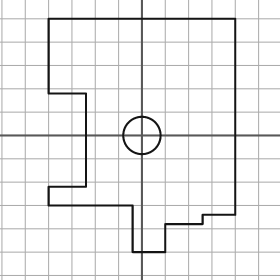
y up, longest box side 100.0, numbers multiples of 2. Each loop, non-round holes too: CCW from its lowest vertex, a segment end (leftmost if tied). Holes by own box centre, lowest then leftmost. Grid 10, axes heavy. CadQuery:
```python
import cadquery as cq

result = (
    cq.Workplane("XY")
    .moveTo(-4.0, -50.0)
    .lineTo(10.0, -50.0)
    .lineTo(10.0, -38.0)
    .lineTo(26.0, -38.0)
    .lineTo(26.0, -34.0)
    .lineTo(40.0, -34.0)
    .lineTo(40.0, 50.0)
    .lineTo(-40.0, 50.0)
    .lineTo(-40.0, 18.0)
    .lineTo(-24.0, 18.0)
    .lineTo(-24.0, -22.0)
    .lineTo(-40.0, -22.0)
    .lineTo(-40.0, -30.0)
    .lineTo(-4.0, -30.0)
    .close()
    .moveTo(0.0, 0.0)
    .circle(8.0)
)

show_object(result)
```